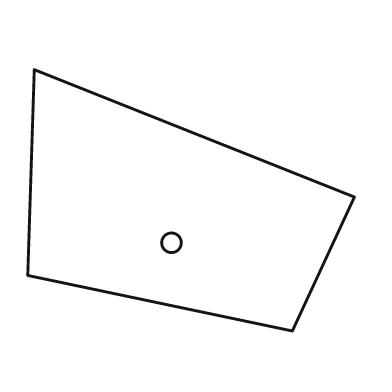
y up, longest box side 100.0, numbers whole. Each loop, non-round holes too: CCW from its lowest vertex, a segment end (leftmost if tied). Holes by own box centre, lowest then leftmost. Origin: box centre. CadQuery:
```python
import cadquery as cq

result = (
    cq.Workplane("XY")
    .moveTo(31.0, -40.0)
    .lineTo(50.0, 1.0)
    .lineTo(-48.0, 40.0)
    .lineTo(-50.0, -23.0)
    .close()
    .moveTo(-6.0, -13.0)
    .circle(3.0)
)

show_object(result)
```